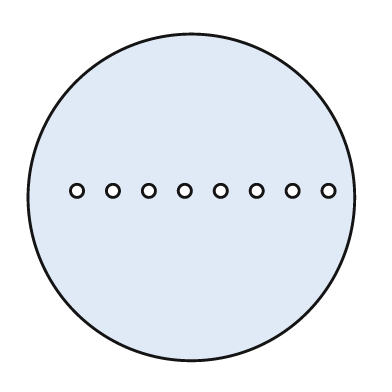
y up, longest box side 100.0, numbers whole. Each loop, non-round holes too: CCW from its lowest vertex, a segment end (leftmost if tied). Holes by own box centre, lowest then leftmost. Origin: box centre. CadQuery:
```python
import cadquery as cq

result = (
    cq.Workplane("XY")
    .moveTo(0.0, 0.0)
    .circle(50.0)
    .moveTo(-35.0, 2.0)
    .circle(2.0)
    .moveTo(-24.0, 2.0)
    .circle(2.0)
    .moveTo(-13.0, 2.0)
    .circle(2.0)
    .moveTo(-2.0, 2.0)
    .circle(2.0)
    .moveTo(9.0, 2.0)
    .circle(2.0)
    .moveTo(20.0, 2.0)
    .circle(2.0)
    .moveTo(31.0, 2.0)
    .circle(2.0)
    .moveTo(42.0, 2.0)
    .circle(2.0)
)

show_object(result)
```